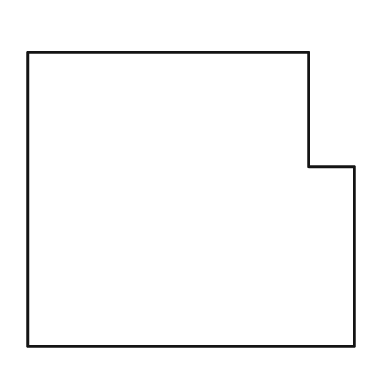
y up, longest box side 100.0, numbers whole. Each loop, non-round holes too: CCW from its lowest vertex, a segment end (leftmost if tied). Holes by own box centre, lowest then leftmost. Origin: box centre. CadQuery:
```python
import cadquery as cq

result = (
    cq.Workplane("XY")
    .moveTo(-50.0, -45.0)
    .lineTo(50.0, -45.0)
    .lineTo(50.0, 10.0)
    .lineTo(36.0, 10.0)
    .lineTo(36.0, 45.0)
    .lineTo(-50.0, 45.0)
    .close()
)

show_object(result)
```